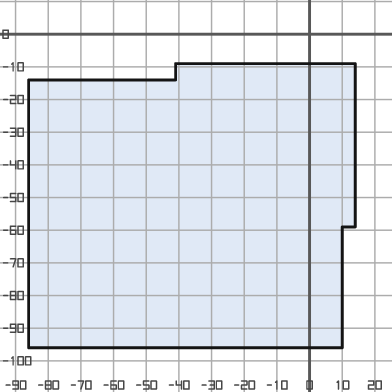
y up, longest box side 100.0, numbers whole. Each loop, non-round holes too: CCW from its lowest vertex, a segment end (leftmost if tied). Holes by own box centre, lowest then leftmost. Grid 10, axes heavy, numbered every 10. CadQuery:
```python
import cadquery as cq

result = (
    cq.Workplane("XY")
    .moveTo(-86.0, -96.0)
    .lineTo(10.0, -96.0)
    .lineTo(10.0, -59.0)
    .lineTo(14.0, -59.0)
    .lineTo(14.0, -9.0)
    .lineTo(-41.0, -9.0)
    .lineTo(-41.0, -14.0)
    .lineTo(-86.0, -14.0)
    .close()
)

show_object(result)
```